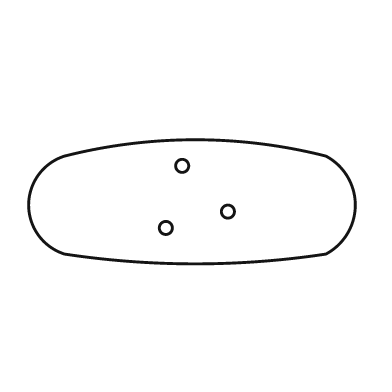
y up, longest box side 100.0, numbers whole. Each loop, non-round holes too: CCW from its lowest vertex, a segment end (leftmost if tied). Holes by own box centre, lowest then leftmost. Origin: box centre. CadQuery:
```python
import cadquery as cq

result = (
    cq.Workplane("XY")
    .moveTo(-39.0, -16.0)
    .threePointArc((1.0, -19.0), (41.0, -16.0))
    .threePointArc((50.0, -1.0), (41.0, 14.0))
    .threePointArc((1.0, 19.0), (-39.0, 14.0))
    .threePointArc((-50.0, -1.0), (-39.0, -16.0))
    .close()
    .moveTo(-8.0, -8.0)
    .circle(2.0)
    .moveTo(11.0, -3.0)
    .circle(2.0)
    .moveTo(-3.0, 11.0)
    .circle(2.0)
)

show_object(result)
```